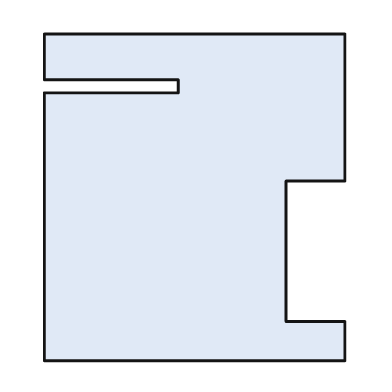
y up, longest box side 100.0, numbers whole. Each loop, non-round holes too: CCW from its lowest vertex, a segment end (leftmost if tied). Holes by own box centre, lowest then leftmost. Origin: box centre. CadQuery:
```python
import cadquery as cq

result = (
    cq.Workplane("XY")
    .moveTo(-46.0, -50.0)
    .lineTo(46.0, -50.0)
    .lineTo(46.0, -38.0)
    .lineTo(28.0, -38.0)
    .lineTo(28.0, 5.0)
    .lineTo(46.0, 5.0)
    .lineTo(46.0, 50.0)
    .lineTo(-46.0, 50.0)
    .lineTo(-46.0, 36.0)
    .lineTo(-5.0, 36.0)
    .lineTo(-5.0, 32.0)
    .lineTo(-46.0, 32.0)
    .close()
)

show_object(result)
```